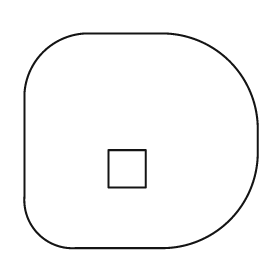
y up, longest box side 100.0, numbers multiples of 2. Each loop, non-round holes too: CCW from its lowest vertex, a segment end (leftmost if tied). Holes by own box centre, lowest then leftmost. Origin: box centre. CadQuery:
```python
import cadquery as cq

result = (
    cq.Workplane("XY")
    .moveTo(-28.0, -46.0)
    .lineTo(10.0, -46.0)
    .threePointArc((38.0, -34.0), (50.0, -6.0))
    .lineTo(50.0, 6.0)
    .threePointArc((38.0, 34.0), (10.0, 46.0))
    .lineTo(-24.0, 46.0)
    .threePointArc((-42.0, 38.0), (-50.0, 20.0))
    .lineTo(-50.0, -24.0)
    .threePointArc((-44.0, -40.0), (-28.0, -46.0))
    .close()
    .moveTo(-14.0, -20.0)
    .lineTo(2.0, -20.0)
    .lineTo(2.0, -4.0)
    .lineTo(-14.0, -4.0)
    .close()
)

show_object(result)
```